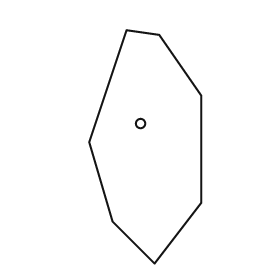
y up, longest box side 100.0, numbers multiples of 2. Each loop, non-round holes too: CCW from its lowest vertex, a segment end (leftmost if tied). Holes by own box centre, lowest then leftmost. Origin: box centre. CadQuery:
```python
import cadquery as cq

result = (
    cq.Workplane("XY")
    .moveTo(4.0, -50.0)
    .lineTo(24.0, -24.0)
    .lineTo(24.0, 22.0)
    .lineTo(6.0, 48.0)
    .lineTo(-8.0, 50.0)
    .lineTo(-24.0, 2.0)
    .lineTo(-14.0, -32.0)
    .close()
    .moveTo(-2.0, 10.0)
    .circle(2.0)
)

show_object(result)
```